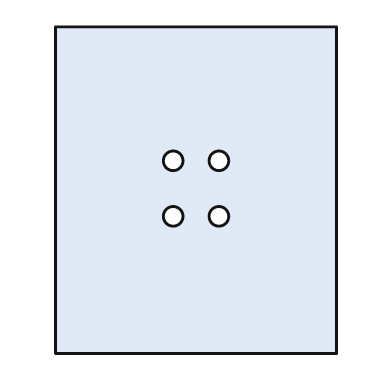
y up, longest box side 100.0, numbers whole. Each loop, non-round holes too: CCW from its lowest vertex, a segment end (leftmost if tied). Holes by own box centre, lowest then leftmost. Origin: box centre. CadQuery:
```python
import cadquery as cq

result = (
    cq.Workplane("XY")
    .moveTo(-43.0, -50.0)
    .lineTo(43.0, -50.0)
    .lineTo(43.0, 50.0)
    .lineTo(-43.0, 50.0)
    .close()
    .moveTo(-7.0, -8.0)
    .circle(3.0)
    .moveTo(7.0, -8.0)
    .circle(3.0)
    .moveTo(-7.0, 9.0)
    .circle(3.0)
    .moveTo(7.0, 9.0)
    .circle(3.0)
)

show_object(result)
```